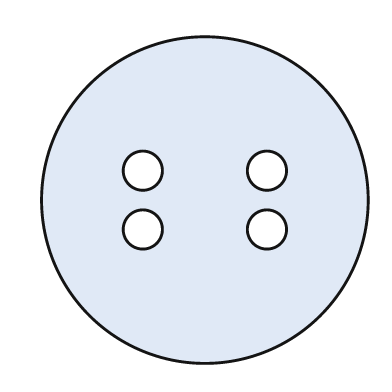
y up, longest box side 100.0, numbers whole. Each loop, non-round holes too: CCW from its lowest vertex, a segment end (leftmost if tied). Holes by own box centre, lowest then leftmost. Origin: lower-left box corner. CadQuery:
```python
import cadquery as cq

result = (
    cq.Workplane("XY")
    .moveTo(50.0, 50.0)
    .circle(50.0)
    .moveTo(31.0, 41.0)
    .circle(6.0)
    .moveTo(69.0, 41.0)
    .circle(6.0)
    .moveTo(31.0, 59.0)
    .circle(6.0)
    .moveTo(69.0, 59.0)
    .circle(6.0)
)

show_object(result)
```